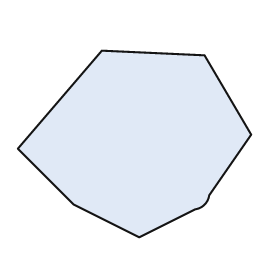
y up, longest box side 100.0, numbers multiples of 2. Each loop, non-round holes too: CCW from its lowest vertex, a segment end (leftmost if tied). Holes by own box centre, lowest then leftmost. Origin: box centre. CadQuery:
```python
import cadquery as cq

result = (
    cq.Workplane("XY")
    .moveTo(2.0, -40.0)
    .lineTo(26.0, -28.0)
    .threePointArc((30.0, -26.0), (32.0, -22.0))
    .lineTo(50.0, 4.0)
    .lineTo(30.0, 38.0)
    .lineTo(-14.0, 40.0)
    .lineTo(-50.0, -2.0)
    .lineTo(-26.0, -26.0)
    .close()
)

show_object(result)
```